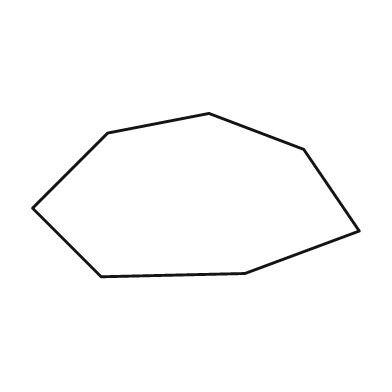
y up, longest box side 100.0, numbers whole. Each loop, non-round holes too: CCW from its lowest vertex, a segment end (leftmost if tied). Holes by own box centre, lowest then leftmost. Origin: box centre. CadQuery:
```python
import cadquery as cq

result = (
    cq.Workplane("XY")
    .moveTo(-29.0, -25.0)
    .lineTo(15.0, -24.0)
    .lineTo(50.0, -11.0)
    .lineTo(33.0, 14.0)
    .lineTo(4.0, 25.0)
    .lineTo(-27.0, 19.0)
    .lineTo(-50.0, -4.0)
    .close()
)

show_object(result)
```